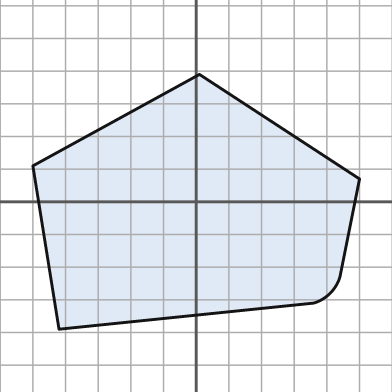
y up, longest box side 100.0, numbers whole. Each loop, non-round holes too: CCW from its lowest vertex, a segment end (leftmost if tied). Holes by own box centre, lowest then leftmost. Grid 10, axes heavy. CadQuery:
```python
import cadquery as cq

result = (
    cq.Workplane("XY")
    .moveTo(-42.0, -39.0)
    .lineTo(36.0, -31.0)
    .threePointArc((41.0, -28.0), (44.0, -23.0))
    .lineTo(50.0, 7.0)
    .lineTo(1.0, 39.0)
    .lineTo(-50.0, 11.0)
    .close()
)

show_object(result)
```